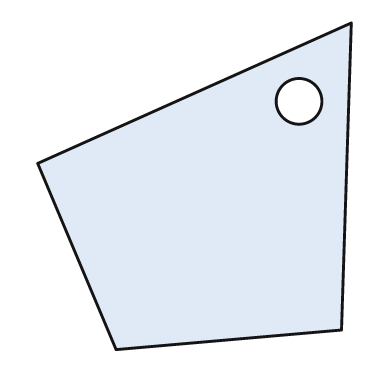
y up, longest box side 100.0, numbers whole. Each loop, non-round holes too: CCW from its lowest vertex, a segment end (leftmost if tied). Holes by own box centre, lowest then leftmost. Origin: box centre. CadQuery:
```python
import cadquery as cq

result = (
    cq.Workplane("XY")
    .moveTo(-24.0, -50.0)
    .lineTo(45.0, -44.0)
    .lineTo(48.0, 50.0)
    .lineTo(-48.0, 7.0)
    .close()
    .moveTo(32.0, 26.0)
    .circle(7.0)
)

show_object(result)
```